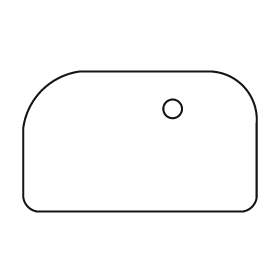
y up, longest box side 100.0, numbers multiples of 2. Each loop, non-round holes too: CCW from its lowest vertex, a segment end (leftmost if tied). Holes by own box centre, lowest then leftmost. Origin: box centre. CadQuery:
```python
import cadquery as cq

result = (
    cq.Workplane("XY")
    .moveTo(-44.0, -30.0)
    .lineTo(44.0, -30.0)
    .threePointArc((48.0, -28.0), (50.0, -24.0))
    .lineTo(50.0, 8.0)
    .threePointArc((44.0, 24.0), (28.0, 30.0))
    .lineTo(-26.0, 30.0)
    .threePointArc((-42.0, 22.0), (-50.0, 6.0))
    .lineTo(-50.0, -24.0)
    .threePointArc((-48.0, -28.0), (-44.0, -30.0))
    .close()
    .moveTo(14.0, 14.0)
    .circle(4.0)
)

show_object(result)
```